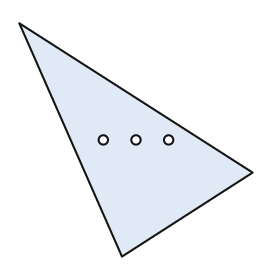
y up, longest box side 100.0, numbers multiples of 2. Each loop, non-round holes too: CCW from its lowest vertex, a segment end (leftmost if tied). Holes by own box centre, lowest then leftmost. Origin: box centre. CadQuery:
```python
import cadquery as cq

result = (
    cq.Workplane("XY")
    .moveTo(-6.0, -50.0)
    .lineTo(50.0, -14.0)
    .lineTo(-50.0, 50.0)
    .close()
    .moveTo(-14.0, 0.0)
    .circle(2.0)
    .moveTo(0.0, 0.0)
    .circle(2.0)
    .moveTo(14.0, 0.0)
    .circle(2.0)
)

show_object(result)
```